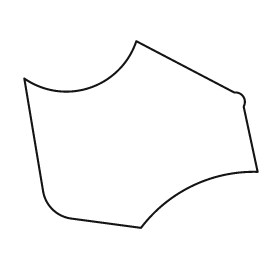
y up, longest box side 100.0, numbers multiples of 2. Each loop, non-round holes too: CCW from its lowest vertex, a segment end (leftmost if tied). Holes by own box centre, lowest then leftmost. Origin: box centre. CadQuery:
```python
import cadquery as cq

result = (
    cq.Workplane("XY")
    .moveTo(0.0, -40.0)
    .threePointArc((22.0, -22.0), (50.0, -16.0))
    .lineTo(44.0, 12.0)
    .threePointArc((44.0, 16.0), (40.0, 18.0))
    .lineTo(-2.0, 40.0)
    .threePointArc((-22.0, 20.0), (-50.0, 24.0))
    .lineTo(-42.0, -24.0)
    .threePointArc((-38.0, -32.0), (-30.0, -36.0))
    .close()
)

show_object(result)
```